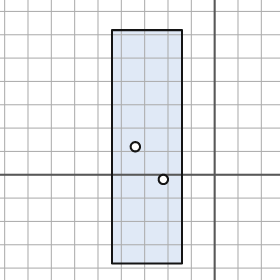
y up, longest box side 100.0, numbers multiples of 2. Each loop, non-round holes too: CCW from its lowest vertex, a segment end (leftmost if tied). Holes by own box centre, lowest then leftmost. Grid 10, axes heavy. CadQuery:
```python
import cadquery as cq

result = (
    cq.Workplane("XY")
    .moveTo(-44.0, -38.0)
    .lineTo(-14.0, -38.0)
    .lineTo(-14.0, 62.0)
    .lineTo(-44.0, 62.0)
    .close()
    .moveTo(-22.0, -2.0)
    .circle(2.0)
    .moveTo(-34.0, 12.0)
    .circle(2.0)
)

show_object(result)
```